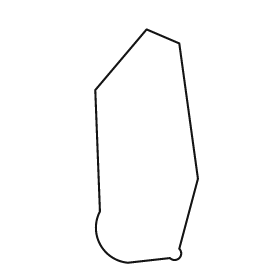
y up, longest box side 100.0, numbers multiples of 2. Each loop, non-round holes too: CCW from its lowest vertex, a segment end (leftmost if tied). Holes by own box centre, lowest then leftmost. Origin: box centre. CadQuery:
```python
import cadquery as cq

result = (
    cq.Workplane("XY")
    .moveTo(-8.0, -50.0)
    .lineTo(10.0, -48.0)
    .threePointArc((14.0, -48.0), (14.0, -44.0))
    .lineTo(22.0, -14.0)
    .lineTo(14.0, 44.0)
    .lineTo(0.0, 50.0)
    .lineTo(-22.0, 24.0)
    .lineTo(-20.0, -28.0)
    .threePointArc((-20.0, -42.0), (-8.0, -50.0))
    .close()
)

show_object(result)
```